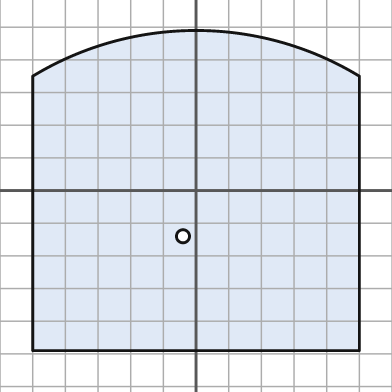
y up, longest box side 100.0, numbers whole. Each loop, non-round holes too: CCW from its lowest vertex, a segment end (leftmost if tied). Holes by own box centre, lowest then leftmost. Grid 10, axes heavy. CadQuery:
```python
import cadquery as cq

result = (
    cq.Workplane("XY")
    .moveTo(-50.0, -49.0)
    .lineTo(50.0, -49.0)
    .lineTo(50.0, 35.0)
    .threePointArc((0.0, 49.0), (-50.0, 35.0))
    .close()
    .moveTo(-4.0, -14.0)
    .circle(2.0)
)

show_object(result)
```